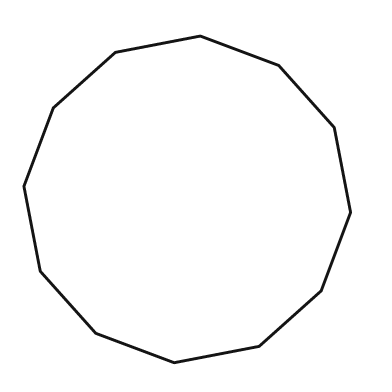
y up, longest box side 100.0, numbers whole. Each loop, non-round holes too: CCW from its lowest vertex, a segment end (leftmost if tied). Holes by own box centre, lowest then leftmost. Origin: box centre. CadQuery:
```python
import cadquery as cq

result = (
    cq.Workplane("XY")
    .moveTo(-4.0, -50.0)
    .lineTo(22.0, -45.0)
    .lineTo(41.0, -28.0)
    .lineTo(50.0, -4.0)
    .lineTo(45.0, 22.0)
    .lineTo(28.0, 41.0)
    .lineTo(4.0, 50.0)
    .lineTo(-22.0, 45.0)
    .lineTo(-41.0, 28.0)
    .lineTo(-50.0, 4.0)
    .lineTo(-45.0, -22.0)
    .lineTo(-28.0, -41.0)
    .close()
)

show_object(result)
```